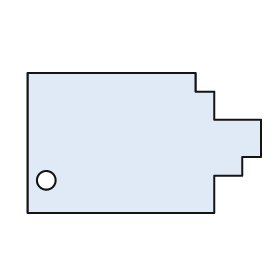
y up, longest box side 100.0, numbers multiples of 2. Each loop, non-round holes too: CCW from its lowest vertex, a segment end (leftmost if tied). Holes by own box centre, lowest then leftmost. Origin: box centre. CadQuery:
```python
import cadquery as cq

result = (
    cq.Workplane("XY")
    .moveTo(-50.0, -30.0)
    .lineTo(30.0, -30.0)
    .lineTo(30.0, -14.0)
    .lineTo(42.0, -14.0)
    .lineTo(42.0, -6.0)
    .lineTo(50.0, -6.0)
    .lineTo(50.0, 10.0)
    .lineTo(30.0, 10.0)
    .lineTo(30.0, 22.0)
    .lineTo(22.0, 22.0)
    .lineTo(22.0, 30.0)
    .lineTo(-50.0, 30.0)
    .close()
    .moveTo(-42.0, -16.0)
    .circle(4.0)
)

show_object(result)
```